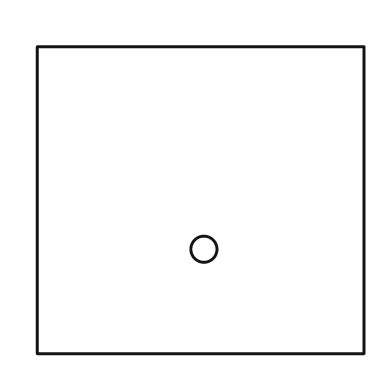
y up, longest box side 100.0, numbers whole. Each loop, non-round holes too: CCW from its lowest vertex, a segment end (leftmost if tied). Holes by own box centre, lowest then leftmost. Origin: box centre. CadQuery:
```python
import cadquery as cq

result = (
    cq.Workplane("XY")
    .moveTo(-50.0, -47.0)
    .lineTo(50.0, -47.0)
    .lineTo(50.0, 47.0)
    .lineTo(-50.0, 47.0)
    .close()
    .moveTo(1.0, -15.0)
    .circle(4.0)
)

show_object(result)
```